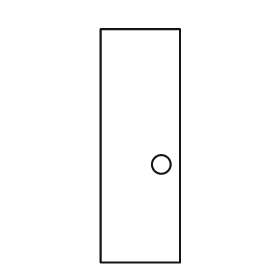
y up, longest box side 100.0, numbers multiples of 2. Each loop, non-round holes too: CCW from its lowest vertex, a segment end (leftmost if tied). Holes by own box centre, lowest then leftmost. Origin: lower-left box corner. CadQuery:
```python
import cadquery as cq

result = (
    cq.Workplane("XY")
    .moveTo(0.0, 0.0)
    .lineTo(34.0, 0.0)
    .lineTo(34.0, 100.0)
    .lineTo(0.0, 100.0)
    .close()
    .moveTo(26.0, 42.0)
    .circle(4.0)
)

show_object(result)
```